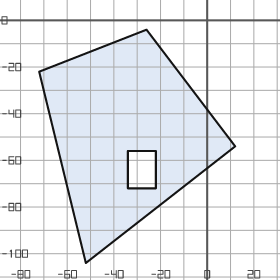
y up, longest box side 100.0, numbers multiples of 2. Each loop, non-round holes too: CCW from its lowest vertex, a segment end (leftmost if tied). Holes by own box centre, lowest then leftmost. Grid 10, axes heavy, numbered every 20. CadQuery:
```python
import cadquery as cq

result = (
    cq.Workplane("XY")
    .moveTo(-52.0, -104.0)
    .lineTo(12.0, -54.0)
    .lineTo(-26.0, -4.0)
    .lineTo(-72.0, -22.0)
    .close()
    .moveTo(-34.0, -72.0)
    .lineTo(-22.0, -72.0)
    .lineTo(-22.0, -56.0)
    .lineTo(-34.0, -56.0)
    .close()
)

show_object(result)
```